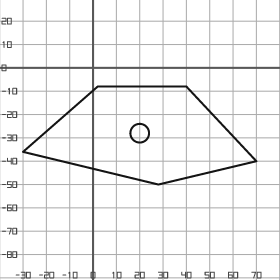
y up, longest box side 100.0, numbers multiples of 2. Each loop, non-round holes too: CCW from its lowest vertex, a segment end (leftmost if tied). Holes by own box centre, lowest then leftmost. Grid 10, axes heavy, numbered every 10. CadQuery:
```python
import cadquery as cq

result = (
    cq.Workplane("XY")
    .moveTo(28.0, -50.0)
    .lineTo(70.0, -40.0)
    .lineTo(40.0, -8.0)
    .lineTo(2.0, -8.0)
    .lineTo(-30.0, -36.0)
    .close()
    .moveTo(20.0, -28.0)
    .circle(4.0)
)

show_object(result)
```